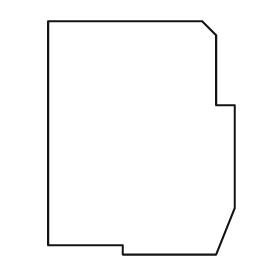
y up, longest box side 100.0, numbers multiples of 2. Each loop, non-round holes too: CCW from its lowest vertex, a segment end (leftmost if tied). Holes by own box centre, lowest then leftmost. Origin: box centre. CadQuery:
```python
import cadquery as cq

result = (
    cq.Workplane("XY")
    .moveTo(-8.0, -50.0)
    .lineTo(32.0, -50.0)
    .lineTo(40.0, -30.0)
    .lineTo(40.0, 14.0)
    .lineTo(32.0, 14.0)
    .lineTo(32.0, 44.0)
    .lineTo(26.0, 50.0)
    .lineTo(-40.0, 50.0)
    .lineTo(-40.0, -46.0)
    .lineTo(-8.0, -46.0)
    .close()
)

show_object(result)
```